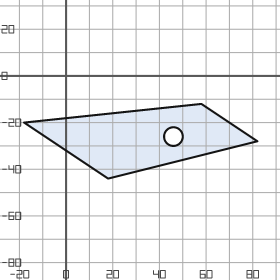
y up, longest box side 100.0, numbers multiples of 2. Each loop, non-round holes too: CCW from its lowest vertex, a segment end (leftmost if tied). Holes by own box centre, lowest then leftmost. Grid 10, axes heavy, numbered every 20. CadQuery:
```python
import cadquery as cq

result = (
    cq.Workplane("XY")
    .moveTo(18.0, -44.0)
    .lineTo(82.0, -28.0)
    .lineTo(58.0, -12.0)
    .lineTo(-18.0, -20.0)
    .close()
    .moveTo(46.0, -26.0)
    .circle(4.0)
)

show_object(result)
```